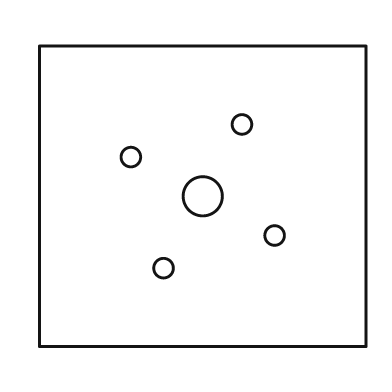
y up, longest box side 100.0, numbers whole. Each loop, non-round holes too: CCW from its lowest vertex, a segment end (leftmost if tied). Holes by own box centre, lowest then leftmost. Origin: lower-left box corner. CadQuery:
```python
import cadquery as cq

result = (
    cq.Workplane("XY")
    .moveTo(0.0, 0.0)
    .lineTo(100.0, 0.0)
    .lineTo(100.0, 92.0)
    .lineTo(0.0, 92.0)
    .close()
    .moveTo(38.0, 24.0)
    .circle(3.0)
    .moveTo(72.0, 34.0)
    .circle(3.0)
    .moveTo(50.0, 46.0)
    .circle(6.0)
    .moveTo(28.0, 58.0)
    .circle(3.0)
    .moveTo(62.0, 68.0)
    .circle(3.0)
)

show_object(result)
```